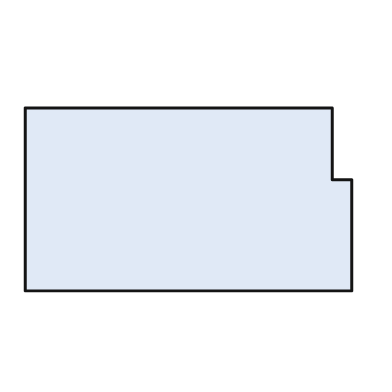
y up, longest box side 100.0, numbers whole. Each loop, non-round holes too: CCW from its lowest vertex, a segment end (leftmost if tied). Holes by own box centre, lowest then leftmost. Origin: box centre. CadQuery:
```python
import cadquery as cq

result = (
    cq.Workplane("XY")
    .moveTo(-50.0, -28.0)
    .lineTo(50.0, -28.0)
    .lineTo(50.0, 6.0)
    .lineTo(44.0, 6.0)
    .lineTo(44.0, 28.0)
    .lineTo(-50.0, 28.0)
    .close()
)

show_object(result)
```